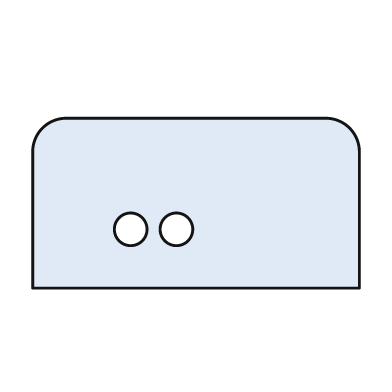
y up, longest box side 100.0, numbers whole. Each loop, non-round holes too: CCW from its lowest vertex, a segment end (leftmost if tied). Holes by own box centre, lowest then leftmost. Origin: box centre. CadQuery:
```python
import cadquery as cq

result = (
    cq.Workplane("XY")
    .moveTo(-50.0, -26.0)
    .lineTo(50.0, -26.0)
    .lineTo(50.0, 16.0)
    .threePointArc((47.0, 23.0), (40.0, 26.0))
    .lineTo(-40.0, 26.0)
    .threePointArc((-47.0, 23.0), (-50.0, 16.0))
    .close()
    .moveTo(-20.0, -8.0)
    .circle(5.0)
    .moveTo(-6.0, -8.0)
    .circle(5.0)
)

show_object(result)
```